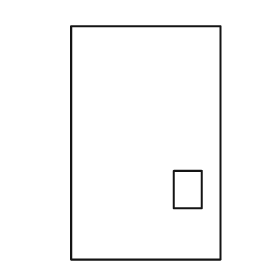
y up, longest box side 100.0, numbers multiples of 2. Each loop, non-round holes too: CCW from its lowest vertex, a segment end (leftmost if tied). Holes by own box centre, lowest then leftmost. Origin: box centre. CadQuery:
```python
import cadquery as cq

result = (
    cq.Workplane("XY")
    .moveTo(-32.0, -50.0)
    .lineTo(32.0, -50.0)
    .lineTo(32.0, 50.0)
    .lineTo(-32.0, 50.0)
    .close()
    .moveTo(12.0, -28.0)
    .lineTo(24.0, -28.0)
    .lineTo(24.0, -12.0)
    .lineTo(12.0, -12.0)
    .close()
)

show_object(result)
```